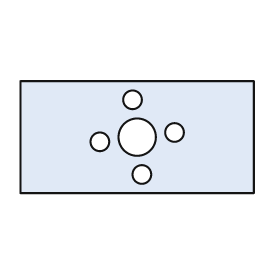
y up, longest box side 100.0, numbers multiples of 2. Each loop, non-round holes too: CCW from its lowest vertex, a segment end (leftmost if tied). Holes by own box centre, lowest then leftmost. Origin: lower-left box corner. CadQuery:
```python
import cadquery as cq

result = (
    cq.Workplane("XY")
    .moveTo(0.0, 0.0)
    .lineTo(100.0, 0.0)
    .lineTo(100.0, 48.0)
    .lineTo(0.0, 48.0)
    .close()
    .moveTo(52.0, 8.0)
    .circle(4.0)
    .moveTo(34.0, 22.0)
    .circle(4.0)
    .moveTo(50.0, 24.0)
    .circle(8.0)
    .moveTo(66.0, 26.0)
    .circle(4.0)
    .moveTo(48.0, 40.0)
    .circle(4.0)
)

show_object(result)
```